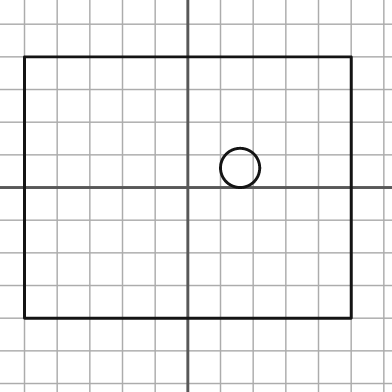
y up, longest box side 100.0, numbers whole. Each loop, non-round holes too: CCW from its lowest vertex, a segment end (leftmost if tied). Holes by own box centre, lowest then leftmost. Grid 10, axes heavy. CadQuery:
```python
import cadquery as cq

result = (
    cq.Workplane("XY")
    .moveTo(-50.0, -40.0)
    .lineTo(50.0, -40.0)
    .lineTo(50.0, 40.0)
    .lineTo(-50.0, 40.0)
    .close()
    .moveTo(16.0, 6.0)
    .circle(6.0)
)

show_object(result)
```